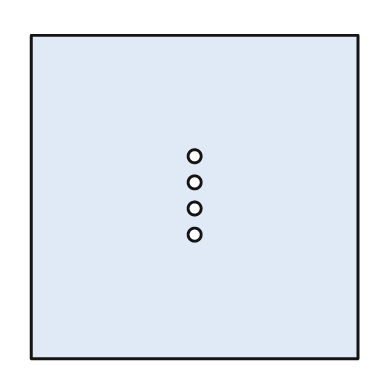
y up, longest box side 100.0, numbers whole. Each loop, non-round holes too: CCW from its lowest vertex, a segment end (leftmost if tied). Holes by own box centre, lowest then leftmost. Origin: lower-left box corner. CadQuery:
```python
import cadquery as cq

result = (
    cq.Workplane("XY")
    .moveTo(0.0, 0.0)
    .lineTo(100.0, 0.0)
    .lineTo(100.0, 99.0)
    .lineTo(0.0, 99.0)
    .close()
    .moveTo(50.0, 38.0)
    .circle(2.0)
    .moveTo(50.0, 46.0)
    .circle(2.0)
    .moveTo(50.0, 54.0)
    .circle(2.0)
    .moveTo(50.0, 62.0)
    .circle(2.0)
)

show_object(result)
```